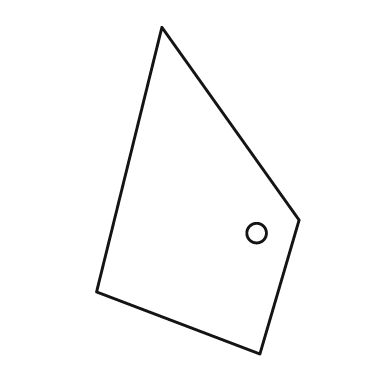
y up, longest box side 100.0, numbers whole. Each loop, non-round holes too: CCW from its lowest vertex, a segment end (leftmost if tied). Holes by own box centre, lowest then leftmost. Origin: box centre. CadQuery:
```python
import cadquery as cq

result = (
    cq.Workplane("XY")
    .moveTo(19.0, -50.0)
    .lineTo(31.0, -9.0)
    .lineTo(-11.0, 50.0)
    .lineTo(-31.0, -31.0)
    .close()
    .moveTo(18.0, -13.0)
    .circle(3.0)
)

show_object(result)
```